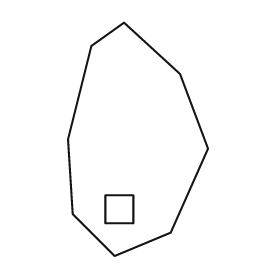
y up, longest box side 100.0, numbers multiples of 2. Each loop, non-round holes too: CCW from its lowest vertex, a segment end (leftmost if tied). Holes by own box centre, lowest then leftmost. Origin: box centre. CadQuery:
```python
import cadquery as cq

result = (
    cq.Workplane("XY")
    .moveTo(-10.0, -50.0)
    .lineTo(14.0, -40.0)
    .lineTo(30.0, -4.0)
    .lineTo(18.0, 28.0)
    .lineTo(-6.0, 50.0)
    .lineTo(-20.0, 40.0)
    .lineTo(-30.0, 0.0)
    .lineTo(-28.0, -32.0)
    .close()
    .moveTo(-14.0, -36.0)
    .lineTo(-2.0, -36.0)
    .lineTo(-2.0, -24.0)
    .lineTo(-14.0, -24.0)
    .close()
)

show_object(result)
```